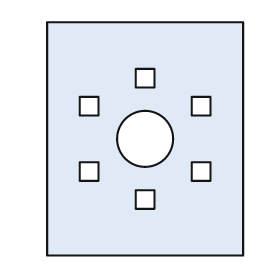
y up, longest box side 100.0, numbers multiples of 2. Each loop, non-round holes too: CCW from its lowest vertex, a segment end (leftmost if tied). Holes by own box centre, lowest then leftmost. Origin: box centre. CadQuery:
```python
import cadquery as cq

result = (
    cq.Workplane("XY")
    .moveTo(-42.0, -50.0)
    .lineTo(42.0, -50.0)
    .lineTo(42.0, 50.0)
    .lineTo(-42.0, 50.0)
    .close()
    .moveTo(-4.0, -30.0)
    .lineTo(4.0, -30.0)
    .lineTo(4.0, -22.0)
    .lineTo(-4.0, -22.0)
    .close()
    .moveTo(-28.0, -18.0)
    .lineTo(-20.0, -18.0)
    .lineTo(-20.0, -10.0)
    .lineTo(-28.0, -10.0)
    .close()
    .moveTo(20.0, -18.0)
    .lineTo(28.0, -18.0)
    .lineTo(28.0, -10.0)
    .lineTo(20.0, -10.0)
    .close()
    .moveTo(0.0, 0.0)
    .circle(12.0)
    .moveTo(-28.0, 10.0)
    .lineTo(-20.0, 10.0)
    .lineTo(-20.0, 18.0)
    .lineTo(-28.0, 18.0)
    .close()
    .moveTo(20.0, 10.0)
    .lineTo(28.0, 10.0)
    .lineTo(28.0, 18.0)
    .lineTo(20.0, 18.0)
    .close()
    .moveTo(-4.0, 22.0)
    .lineTo(4.0, 22.0)
    .lineTo(4.0, 30.0)
    .lineTo(-4.0, 30.0)
    .close()
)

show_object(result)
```